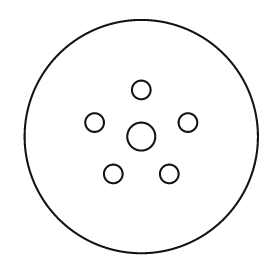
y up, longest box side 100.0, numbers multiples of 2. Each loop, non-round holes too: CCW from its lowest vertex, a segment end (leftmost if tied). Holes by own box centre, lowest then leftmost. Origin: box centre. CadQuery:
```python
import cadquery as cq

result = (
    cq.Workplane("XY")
    .moveTo(0.0, 0.0)
    .circle(50.0)
    .moveTo(-12.0, -16.0)
    .circle(4.0)
    .moveTo(12.0, -16.0)
    .circle(4.0)
    .moveTo(0.0, 0.0)
    .circle(6.0)
    .moveTo(-20.0, 6.0)
    .circle(4.0)
    .moveTo(20.0, 6.0)
    .circle(4.0)
    .moveTo(0.0, 20.0)
    .circle(4.0)
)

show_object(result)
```